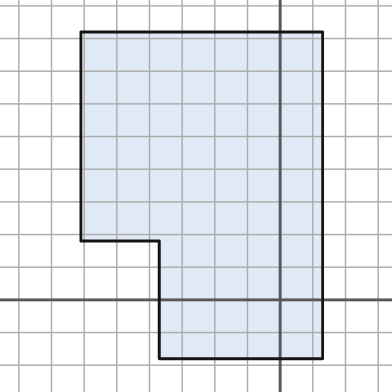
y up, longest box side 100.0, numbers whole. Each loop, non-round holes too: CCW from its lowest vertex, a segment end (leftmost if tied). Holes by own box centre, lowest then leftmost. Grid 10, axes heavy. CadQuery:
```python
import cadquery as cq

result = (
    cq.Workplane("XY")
    .moveTo(-37.0, -18.0)
    .lineTo(13.0, -18.0)
    .lineTo(13.0, 82.0)
    .lineTo(-61.0, 82.0)
    .lineTo(-61.0, 18.0)
    .lineTo(-37.0, 18.0)
    .close()
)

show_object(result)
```